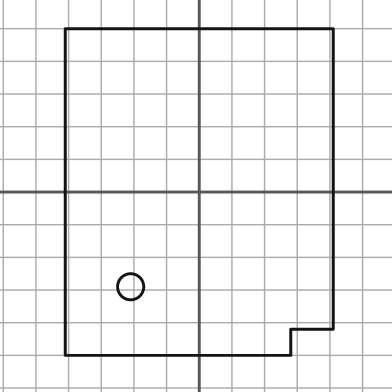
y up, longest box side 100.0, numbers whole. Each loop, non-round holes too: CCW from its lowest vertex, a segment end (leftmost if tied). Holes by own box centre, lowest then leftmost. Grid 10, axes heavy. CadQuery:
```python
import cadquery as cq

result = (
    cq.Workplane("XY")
    .moveTo(-41.0, -50.0)
    .lineTo(28.0, -50.0)
    .lineTo(28.0, -42.0)
    .lineTo(41.0, -42.0)
    .lineTo(41.0, 50.0)
    .lineTo(-41.0, 50.0)
    .close()
    .moveTo(-21.0, -29.0)
    .circle(4.0)
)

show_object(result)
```